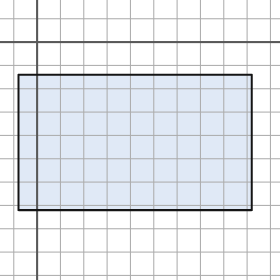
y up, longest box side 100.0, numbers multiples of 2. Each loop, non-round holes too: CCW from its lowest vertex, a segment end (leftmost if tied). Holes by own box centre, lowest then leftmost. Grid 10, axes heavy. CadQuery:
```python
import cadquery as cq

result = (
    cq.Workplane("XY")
    .moveTo(-8.0, -72.0)
    .lineTo(92.0, -72.0)
    .lineTo(92.0, -14.0)
    .lineTo(-8.0, -14.0)
    .close()
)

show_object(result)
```